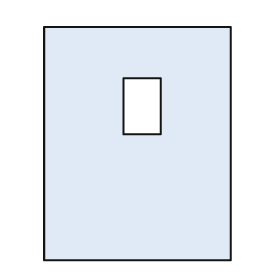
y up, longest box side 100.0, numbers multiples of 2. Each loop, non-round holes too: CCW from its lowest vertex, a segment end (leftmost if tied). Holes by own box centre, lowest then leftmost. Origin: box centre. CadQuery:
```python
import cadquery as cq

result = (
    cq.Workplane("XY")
    .moveTo(-40.0, -50.0)
    .lineTo(40.0, -50.0)
    .lineTo(40.0, 50.0)
    .lineTo(-40.0, 50.0)
    .close()
    .moveTo(-6.0, 4.0)
    .lineTo(10.0, 4.0)
    .lineTo(10.0, 28.0)
    .lineTo(-6.0, 28.0)
    .close()
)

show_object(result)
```